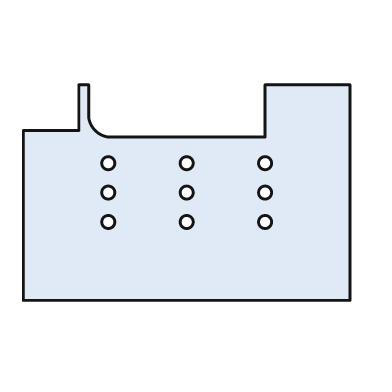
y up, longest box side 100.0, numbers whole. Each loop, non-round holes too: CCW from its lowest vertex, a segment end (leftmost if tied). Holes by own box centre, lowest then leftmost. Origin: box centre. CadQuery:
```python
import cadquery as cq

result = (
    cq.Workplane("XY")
    .moveTo(-50.0, -33.0)
    .lineTo(50.0, -33.0)
    .lineTo(50.0, 33.0)
    .lineTo(24.0, 33.0)
    .lineTo(24.0, 17.0)
    .lineTo(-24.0, 17.0)
    .threePointArc((-28.0, 19.0), (-30.0, 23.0))
    .lineTo(-30.0, 33.0)
    .lineTo(-33.0, 33.0)
    .lineTo(-33.0, 19.0)
    .lineTo(-50.0, 19.0)
    .close()
    .moveTo(-24.0, -9.0)
    .circle(2.0)
    .moveTo(0.0, -9.0)
    .circle(2.0)
    .moveTo(24.0, -9.0)
    .circle(2.0)
    .moveTo(-24.0, 0.0)
    .circle(2.0)
    .moveTo(0.0, 0.0)
    .circle(2.0)
    .moveTo(24.0, 0.0)
    .circle(2.0)
    .moveTo(-24.0, 9.0)
    .circle(2.0)
    .moveTo(0.0, 9.0)
    .circle(2.0)
    .moveTo(24.0, 9.0)
    .circle(2.0)
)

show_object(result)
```